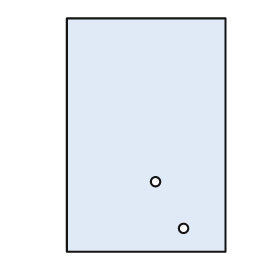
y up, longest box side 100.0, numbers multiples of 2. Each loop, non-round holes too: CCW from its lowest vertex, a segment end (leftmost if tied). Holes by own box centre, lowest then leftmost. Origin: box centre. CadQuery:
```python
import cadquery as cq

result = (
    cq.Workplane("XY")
    .moveTo(-34.0, -50.0)
    .lineTo(34.0, -50.0)
    .lineTo(34.0, 50.0)
    .lineTo(-34.0, 50.0)
    .close()
    .moveTo(16.0, -40.0)
    .circle(2.0)
    .moveTo(4.0, -20.0)
    .circle(2.0)
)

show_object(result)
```